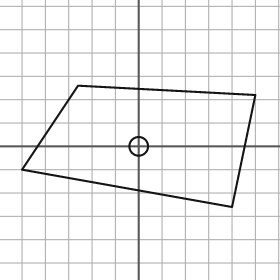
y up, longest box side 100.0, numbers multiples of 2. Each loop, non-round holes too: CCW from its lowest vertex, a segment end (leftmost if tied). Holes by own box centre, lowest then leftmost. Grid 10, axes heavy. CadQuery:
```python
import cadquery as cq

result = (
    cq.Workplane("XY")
    .moveTo(40.0, -26.0)
    .lineTo(50.0, 22.0)
    .lineTo(-26.0, 26.0)
    .lineTo(-50.0, -10.0)
    .close()
    .moveTo(0.0, 0.0)
    .circle(4.0)
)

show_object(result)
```